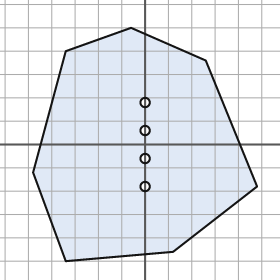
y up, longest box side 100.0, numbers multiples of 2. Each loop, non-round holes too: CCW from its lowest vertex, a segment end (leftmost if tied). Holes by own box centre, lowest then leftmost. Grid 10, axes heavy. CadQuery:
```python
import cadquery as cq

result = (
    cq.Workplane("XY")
    .moveTo(-34.0, -50.0)
    .lineTo(12.0, -46.0)
    .lineTo(48.0, -18.0)
    .lineTo(26.0, 36.0)
    .lineTo(-6.0, 50.0)
    .lineTo(-34.0, 40.0)
    .lineTo(-48.0, -12.0)
    .close()
    .moveTo(0.0, -18.0)
    .circle(2.0)
    .moveTo(0.0, -6.0)
    .circle(2.0)
    .moveTo(0.0, 6.0)
    .circle(2.0)
    .moveTo(0.0, 18.0)
    .circle(2.0)
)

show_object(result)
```